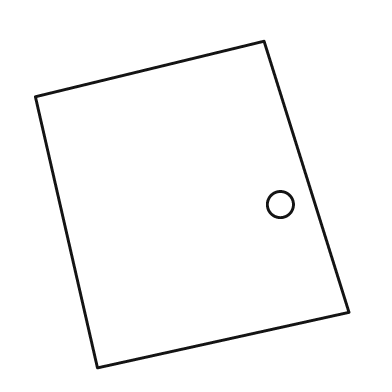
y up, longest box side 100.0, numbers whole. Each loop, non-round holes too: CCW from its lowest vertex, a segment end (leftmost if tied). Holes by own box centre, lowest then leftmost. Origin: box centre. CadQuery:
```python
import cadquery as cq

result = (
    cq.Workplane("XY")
    .moveTo(-29.0, -50.0)
    .lineTo(48.0, -33.0)
    .lineTo(22.0, 50.0)
    .lineTo(-48.0, 33.0)
    .close()
    .moveTo(27.0, 0.0)
    .circle(4.0)
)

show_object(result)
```